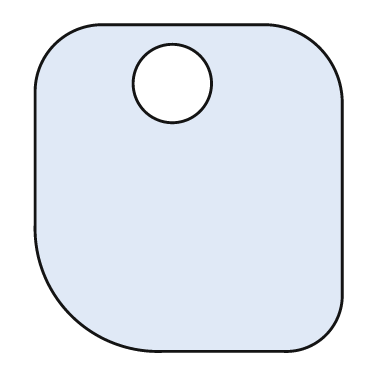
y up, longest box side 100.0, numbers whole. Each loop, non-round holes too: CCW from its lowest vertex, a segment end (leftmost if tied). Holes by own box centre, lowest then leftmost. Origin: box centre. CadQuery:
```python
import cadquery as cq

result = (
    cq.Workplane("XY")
    .moveTo(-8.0, -50.0)
    .lineTo(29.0, -50.0)
    .threePointArc((42.0, -45.0), (47.0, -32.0))
    .lineTo(47.0, 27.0)
    .threePointArc((40.0, 43.0), (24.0, 50.0))
    .lineTo(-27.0, 50.0)
    .threePointArc((-41.0, 44.0), (-47.0, 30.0))
    .lineTo(-47.0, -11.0)
    .threePointArc((-36.0, -39.0), (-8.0, -50.0))
    .close()
    .moveTo(-5.0, 32.0)
    .circle(12.0)
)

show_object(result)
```